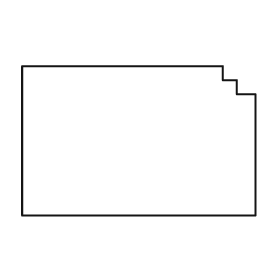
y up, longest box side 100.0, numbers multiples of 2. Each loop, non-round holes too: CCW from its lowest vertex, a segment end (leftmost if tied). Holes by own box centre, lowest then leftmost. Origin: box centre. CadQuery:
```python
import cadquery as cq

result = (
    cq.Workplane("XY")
    .moveTo(-50.0, -32.0)
    .lineTo(50.0, -32.0)
    .lineTo(50.0, 20.0)
    .lineTo(42.0, 20.0)
    .lineTo(42.0, 26.0)
    .lineTo(36.0, 26.0)
    .lineTo(36.0, 32.0)
    .lineTo(-50.0, 32.0)
    .close()
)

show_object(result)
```